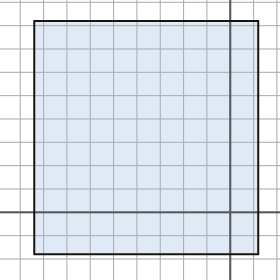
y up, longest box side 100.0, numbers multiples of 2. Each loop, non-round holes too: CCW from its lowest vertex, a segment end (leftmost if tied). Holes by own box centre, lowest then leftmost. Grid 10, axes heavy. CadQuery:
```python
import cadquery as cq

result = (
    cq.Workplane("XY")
    .moveTo(-84.0, -18.0)
    .lineTo(12.0, -18.0)
    .lineTo(12.0, 82.0)
    .lineTo(-84.0, 82.0)
    .close()
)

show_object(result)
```